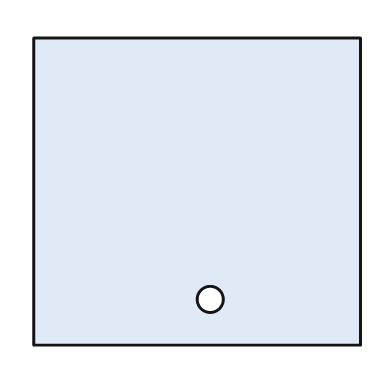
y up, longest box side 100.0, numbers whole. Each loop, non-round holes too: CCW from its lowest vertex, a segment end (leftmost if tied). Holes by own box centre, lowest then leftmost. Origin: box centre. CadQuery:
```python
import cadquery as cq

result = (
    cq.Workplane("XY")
    .moveTo(-50.0, -47.0)
    .lineTo(50.0, -47.0)
    .lineTo(50.0, 47.0)
    .lineTo(-50.0, 47.0)
    .close()
    .moveTo(4.0, -33.0)
    .circle(4.0)
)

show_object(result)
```